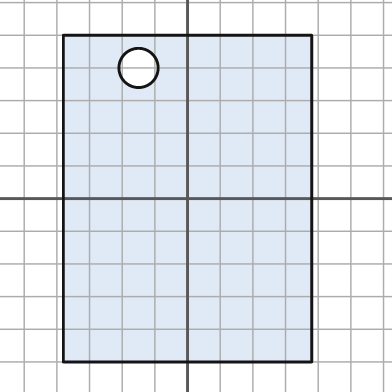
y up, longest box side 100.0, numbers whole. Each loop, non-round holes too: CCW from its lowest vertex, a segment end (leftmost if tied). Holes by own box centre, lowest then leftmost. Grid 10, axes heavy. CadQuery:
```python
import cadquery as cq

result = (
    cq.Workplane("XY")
    .moveTo(-38.0, -50.0)
    .lineTo(38.0, -50.0)
    .lineTo(38.0, 50.0)
    .lineTo(-38.0, 50.0)
    .close()
    .moveTo(-15.0, 40.0)
    .circle(6.0)
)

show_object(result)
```